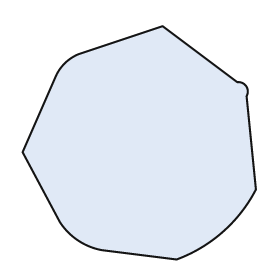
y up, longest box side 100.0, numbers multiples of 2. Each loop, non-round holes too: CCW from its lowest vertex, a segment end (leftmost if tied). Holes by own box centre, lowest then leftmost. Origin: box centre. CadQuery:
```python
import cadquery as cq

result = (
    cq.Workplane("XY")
    .moveTo(16.0, -50.0)
    .threePointArc((36.0, -38.0), (50.0, -20.0))
    .lineTo(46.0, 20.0)
    .threePointArc((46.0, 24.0), (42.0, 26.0))
    .lineTo(10.0, 50.0)
    .lineTo(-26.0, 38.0)
    .threePointArc((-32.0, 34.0), (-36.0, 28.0))
    .lineTo(-50.0, -4.0)
    .lineTo(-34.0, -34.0)
    .threePointArc((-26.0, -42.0), (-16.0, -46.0))
    .close()
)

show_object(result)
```